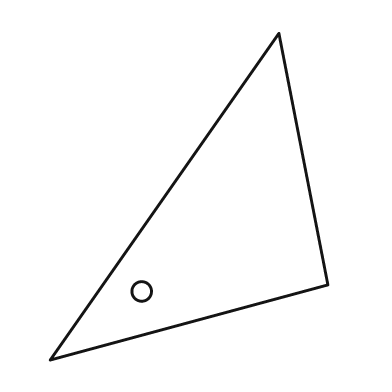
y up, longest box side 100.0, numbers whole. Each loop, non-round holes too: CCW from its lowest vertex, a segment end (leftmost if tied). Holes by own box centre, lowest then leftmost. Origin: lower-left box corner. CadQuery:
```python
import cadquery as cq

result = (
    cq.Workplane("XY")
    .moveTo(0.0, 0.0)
    .lineTo(85.0, 23.0)
    .lineTo(70.0, 100.0)
    .close()
    .moveTo(28.0, 21.0)
    .circle(3.0)
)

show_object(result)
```